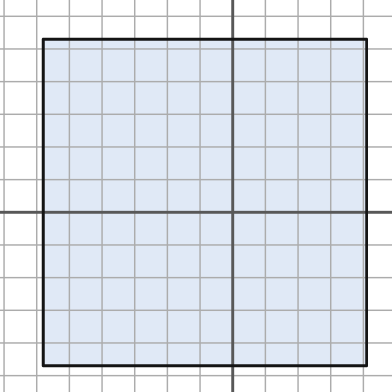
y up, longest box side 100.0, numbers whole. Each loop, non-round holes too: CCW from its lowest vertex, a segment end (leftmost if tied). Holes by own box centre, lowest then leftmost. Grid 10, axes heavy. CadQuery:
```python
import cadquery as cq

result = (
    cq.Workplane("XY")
    .moveTo(-58.0, -47.0)
    .lineTo(41.0, -47.0)
    .lineTo(41.0, 53.0)
    .lineTo(-58.0, 53.0)
    .close()
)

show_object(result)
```